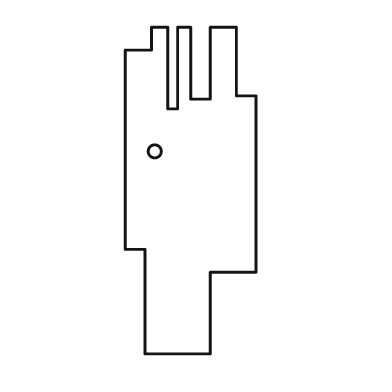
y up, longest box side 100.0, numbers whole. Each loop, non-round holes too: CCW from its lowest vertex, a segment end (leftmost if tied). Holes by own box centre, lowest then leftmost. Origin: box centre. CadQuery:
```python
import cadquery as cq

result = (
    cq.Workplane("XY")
    .moveTo(-14.0, -50.0)
    .lineTo(6.0, -50.0)
    .lineTo(6.0, -25.0)
    .lineTo(20.0, -25.0)
    .lineTo(20.0, 29.0)
    .lineTo(14.0, 29.0)
    .lineTo(14.0, 50.0)
    .lineTo(6.0, 50.0)
    .lineTo(6.0, 28.0)
    .lineTo(0.0, 28.0)
    .lineTo(0.0, 50.0)
    .lineTo(-4.0, 50.0)
    .lineTo(-4.0, 25.0)
    .lineTo(-7.0, 25.0)
    .lineTo(-7.0, 50.0)
    .lineTo(-12.0, 50.0)
    .lineTo(-12.0, 43.0)
    .lineTo(-20.0, 43.0)
    .lineTo(-20.0, -18.0)
    .lineTo(-14.0, -18.0)
    .close()
    .moveTo(-11.0, 12.0)
    .circle(2.0)
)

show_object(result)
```